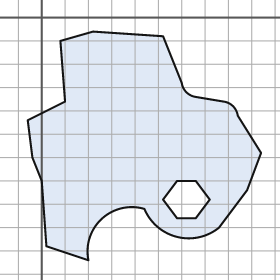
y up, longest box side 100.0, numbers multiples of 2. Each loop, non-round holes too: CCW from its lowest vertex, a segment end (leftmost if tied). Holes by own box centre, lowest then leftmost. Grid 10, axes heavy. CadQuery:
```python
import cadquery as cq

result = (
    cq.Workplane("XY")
    .moveTo(20.0, -104.0)
    .threePointArc((26.0, -86.0), (44.0, -82.0))
    .threePointArc((58.0, -94.0), (76.0, -90.0))
    .lineTo(88.0, -74.0)
    .lineTo(94.0, -58.0)
    .lineTo(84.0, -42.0)
    .threePointArc((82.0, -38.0), (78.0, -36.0))
    .lineTo(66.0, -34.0)
    .threePointArc((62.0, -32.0), (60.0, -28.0))
    .lineTo(52.0, -8.0)
    .lineTo(22.0, -6.0)
    .lineTo(8.0, -10.0)
    .lineTo(10.0, -36.0)
    .lineTo(-6.0, -44.0)
    .lineTo(-4.0, -60.0)
    .lineTo(0.0, -70.0)
    .lineTo(2.0, -98.0)
    .close()
    .moveTo(58.0, -86.0)
    .lineTo(66.0, -86.0)
    .lineTo(72.0, -78.0)
    .lineTo(66.0, -70.0)
    .lineTo(58.0, -70.0)
    .lineTo(52.0, -78.0)
    .close()
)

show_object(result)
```